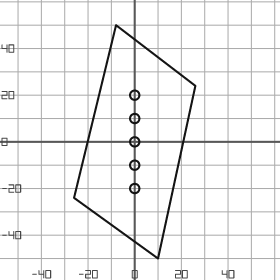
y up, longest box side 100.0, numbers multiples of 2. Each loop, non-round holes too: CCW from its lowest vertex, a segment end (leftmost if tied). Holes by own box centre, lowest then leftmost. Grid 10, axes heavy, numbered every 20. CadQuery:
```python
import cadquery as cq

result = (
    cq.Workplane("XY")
    .moveTo(10.0, -50.0)
    .lineTo(26.0, 24.0)
    .lineTo(-8.0, 50.0)
    .lineTo(-26.0, -24.0)
    .close()
    .moveTo(0.0, -20.0)
    .circle(2.0)
    .moveTo(0.0, -10.0)
    .circle(2.0)
    .moveTo(0.0, 0.0)
    .circle(2.0)
    .moveTo(0.0, 10.0)
    .circle(2.0)
    .moveTo(0.0, 20.0)
    .circle(2.0)
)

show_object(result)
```